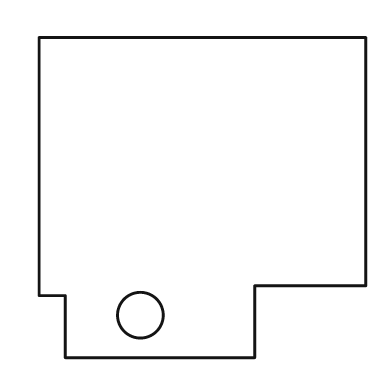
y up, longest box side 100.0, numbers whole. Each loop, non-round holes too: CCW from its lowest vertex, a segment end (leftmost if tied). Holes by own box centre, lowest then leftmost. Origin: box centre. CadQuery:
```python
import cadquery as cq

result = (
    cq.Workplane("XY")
    .moveTo(-42.0, -49.0)
    .lineTo(16.0, -49.0)
    .lineTo(16.0, -27.0)
    .lineTo(50.0, -27.0)
    .lineTo(50.0, 49.0)
    .lineTo(-50.0, 49.0)
    .lineTo(-50.0, -30.0)
    .lineTo(-42.0, -30.0)
    .close()
    .moveTo(-19.0, -36.0)
    .circle(7.0)
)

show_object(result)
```